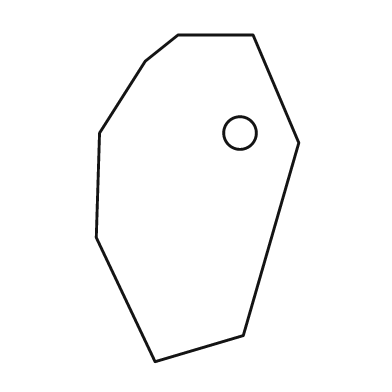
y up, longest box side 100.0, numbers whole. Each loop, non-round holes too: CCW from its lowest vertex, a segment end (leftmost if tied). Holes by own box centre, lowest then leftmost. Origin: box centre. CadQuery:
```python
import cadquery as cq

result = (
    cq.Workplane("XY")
    .moveTo(-13.0, -50.0)
    .lineTo(14.0, -42.0)
    .lineTo(31.0, 17.0)
    .lineTo(17.0, 50.0)
    .lineTo(-6.0, 50.0)
    .lineTo(-16.0, 42.0)
    .lineTo(-30.0, 20.0)
    .lineTo(-31.0, -12.0)
    .close()
    .moveTo(13.0, 20.0)
    .circle(5.0)
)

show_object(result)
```